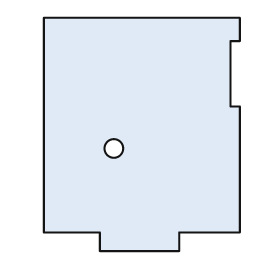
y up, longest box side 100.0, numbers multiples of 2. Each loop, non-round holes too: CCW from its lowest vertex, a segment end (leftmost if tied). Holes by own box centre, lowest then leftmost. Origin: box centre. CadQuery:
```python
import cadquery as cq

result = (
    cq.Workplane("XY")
    .moveTo(-18.0, -50.0)
    .lineTo(16.0, -50.0)
    .lineTo(16.0, -42.0)
    .lineTo(42.0, -42.0)
    .lineTo(42.0, 12.0)
    .lineTo(38.0, 12.0)
    .lineTo(38.0, 40.0)
    .lineTo(42.0, 40.0)
    .lineTo(42.0, 50.0)
    .lineTo(-42.0, 50.0)
    .lineTo(-42.0, -42.0)
    .lineTo(-18.0, -42.0)
    .close()
    .moveTo(-12.0, -6.0)
    .circle(4.0)
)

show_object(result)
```